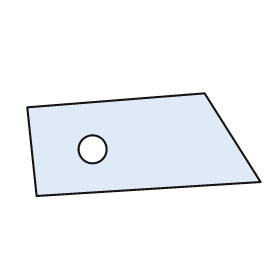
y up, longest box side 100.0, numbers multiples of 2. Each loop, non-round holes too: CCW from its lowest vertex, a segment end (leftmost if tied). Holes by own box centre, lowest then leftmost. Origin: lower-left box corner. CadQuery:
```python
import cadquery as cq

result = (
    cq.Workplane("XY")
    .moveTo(4.0, 0.0)
    .lineTo(100.0, 6.0)
    .lineTo(76.0, 44.0)
    .lineTo(0.0, 38.0)
    .close()
    .moveTo(28.0, 20.0)
    .circle(6.0)
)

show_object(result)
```